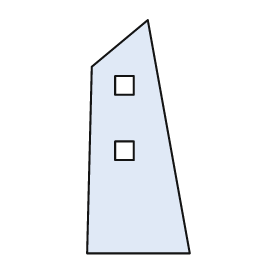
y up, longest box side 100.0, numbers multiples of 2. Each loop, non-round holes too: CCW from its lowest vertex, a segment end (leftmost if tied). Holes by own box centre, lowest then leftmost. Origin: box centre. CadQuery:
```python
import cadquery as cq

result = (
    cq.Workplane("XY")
    .moveTo(-22.0, -50.0)
    .lineTo(22.0, -50.0)
    .lineTo(4.0, 50.0)
    .lineTo(-20.0, 30.0)
    .close()
    .moveTo(-10.0, -10.0)
    .lineTo(-2.0, -10.0)
    .lineTo(-2.0, -2.0)
    .lineTo(-10.0, -2.0)
    .close()
    .moveTo(-10.0, 18.0)
    .lineTo(-2.0, 18.0)
    .lineTo(-2.0, 26.0)
    .lineTo(-10.0, 26.0)
    .close()
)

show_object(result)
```